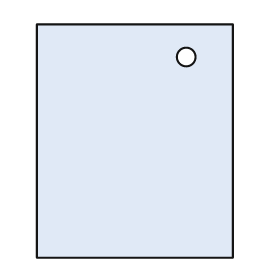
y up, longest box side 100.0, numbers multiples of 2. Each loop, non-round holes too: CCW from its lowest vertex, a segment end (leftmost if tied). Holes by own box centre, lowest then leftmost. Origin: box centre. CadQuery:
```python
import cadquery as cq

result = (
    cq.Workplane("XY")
    .moveTo(-42.0, -50.0)
    .lineTo(42.0, -50.0)
    .lineTo(42.0, 50.0)
    .lineTo(-42.0, 50.0)
    .close()
    .moveTo(22.0, 36.0)
    .circle(4.0)
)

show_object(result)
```